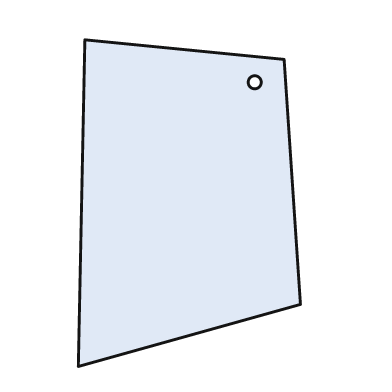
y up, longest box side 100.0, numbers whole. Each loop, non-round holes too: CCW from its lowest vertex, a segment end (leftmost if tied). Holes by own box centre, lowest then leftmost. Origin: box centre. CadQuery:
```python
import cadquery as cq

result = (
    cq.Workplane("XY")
    .moveTo(-34.0, -50.0)
    .lineTo(34.0, -31.0)
    .lineTo(29.0, 44.0)
    .lineTo(-32.0, 50.0)
    .close()
    .moveTo(20.0, 37.0)
    .circle(2.0)
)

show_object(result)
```